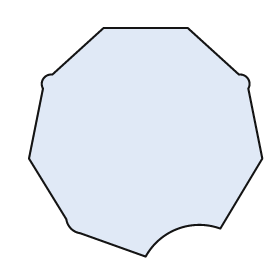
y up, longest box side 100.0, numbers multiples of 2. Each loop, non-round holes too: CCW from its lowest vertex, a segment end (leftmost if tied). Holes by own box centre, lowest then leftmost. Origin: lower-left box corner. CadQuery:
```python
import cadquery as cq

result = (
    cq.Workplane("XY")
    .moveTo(50.0, 0.0)
    .threePointArc((64.0, 12.0), (82.0, 12.0))
    .lineTo(100.0, 42.0)
    .lineTo(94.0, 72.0)
    .threePointArc((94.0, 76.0), (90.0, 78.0))
    .lineTo(68.0, 98.0)
    .lineTo(32.0, 98.0)
    .lineTo(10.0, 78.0)
    .threePointArc((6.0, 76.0), (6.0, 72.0))
    .lineTo(0.0, 42.0)
    .lineTo(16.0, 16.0)
    .threePointArc((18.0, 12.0), (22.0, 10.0))
    .close()
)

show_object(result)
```